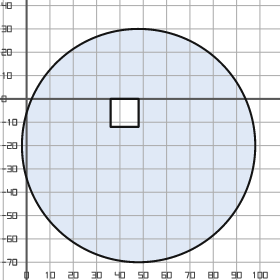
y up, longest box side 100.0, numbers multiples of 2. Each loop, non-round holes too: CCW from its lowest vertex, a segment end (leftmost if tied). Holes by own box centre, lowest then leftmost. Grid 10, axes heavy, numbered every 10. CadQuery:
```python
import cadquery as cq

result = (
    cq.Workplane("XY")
    .moveTo(48.0, -20.0)
    .circle(50.0)
    .moveTo(36.0, -12.0)
    .lineTo(48.0, -12.0)
    .lineTo(48.0, 0.0)
    .lineTo(36.0, 0.0)
    .close()
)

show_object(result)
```